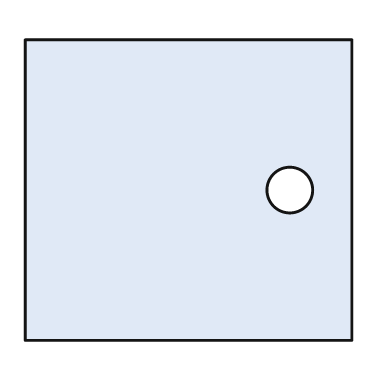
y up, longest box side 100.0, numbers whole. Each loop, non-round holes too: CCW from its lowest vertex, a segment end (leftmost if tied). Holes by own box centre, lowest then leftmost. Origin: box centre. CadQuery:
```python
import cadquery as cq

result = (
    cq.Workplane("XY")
    .moveTo(-50.0, -46.0)
    .lineTo(50.0, -46.0)
    .lineTo(50.0, 46.0)
    .lineTo(-50.0, 46.0)
    .close()
    .moveTo(31.0, 0.0)
    .circle(7.0)
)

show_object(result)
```